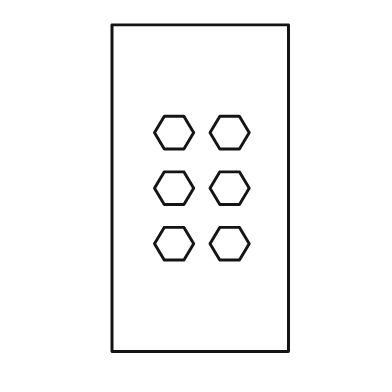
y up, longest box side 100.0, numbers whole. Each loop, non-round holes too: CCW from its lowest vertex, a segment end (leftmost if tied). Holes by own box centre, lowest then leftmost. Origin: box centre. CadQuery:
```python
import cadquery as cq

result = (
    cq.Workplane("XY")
    .moveTo(-27.0, -50.0)
    .lineTo(27.0, -50.0)
    .lineTo(27.0, 50.0)
    .lineTo(-27.0, 50.0)
    .close()
    .moveTo(-11.0, -22.0)
    .lineTo(-5.0, -22.0)
    .lineTo(-2.0, -17.0)
    .lineTo(-5.0, -12.0)
    .lineTo(-11.0, -12.0)
    .lineTo(-14.0, -17.0)
    .close()
    .moveTo(6.0, -22.0)
    .lineTo(12.0, -22.0)
    .lineTo(15.0, -17.0)
    .lineTo(12.0, -12.0)
    .lineTo(6.0, -12.0)
    .lineTo(3.0, -17.0)
    .close()
    .moveTo(-11.0, -5.0)
    .lineTo(-5.0, -5.0)
    .lineTo(-2.0, 0.0)
    .lineTo(-5.0, 5.0)
    .lineTo(-11.0, 5.0)
    .lineTo(-14.0, 0.0)
    .close()
    .moveTo(6.0, -5.0)
    .lineTo(12.0, -5.0)
    .lineTo(15.0, 0.0)
    .lineTo(12.0, 5.0)
    .lineTo(6.0, 5.0)
    .lineTo(3.0, 0.0)
    .close()
    .moveTo(-11.0, 12.0)
    .lineTo(-5.0, 12.0)
    .lineTo(-2.0, 17.0)
    .lineTo(-5.0, 22.0)
    .lineTo(-11.0, 22.0)
    .lineTo(-14.0, 17.0)
    .close()
    .moveTo(6.0, 12.0)
    .lineTo(12.0, 12.0)
    .lineTo(15.0, 17.0)
    .lineTo(12.0, 22.0)
    .lineTo(6.0, 22.0)
    .lineTo(3.0, 17.0)
    .close()
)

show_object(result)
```